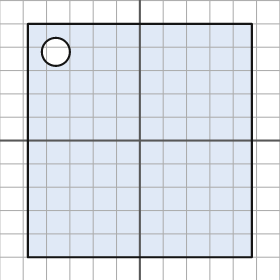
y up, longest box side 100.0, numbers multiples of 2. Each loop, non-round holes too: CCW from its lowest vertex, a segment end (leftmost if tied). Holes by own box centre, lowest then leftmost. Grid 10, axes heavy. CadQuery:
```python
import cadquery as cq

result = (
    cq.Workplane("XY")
    .moveTo(-48.0, -50.0)
    .lineTo(48.0, -50.0)
    .lineTo(48.0, 50.0)
    .lineTo(-48.0, 50.0)
    .close()
    .moveTo(-36.0, 38.0)
    .circle(6.0)
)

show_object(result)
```